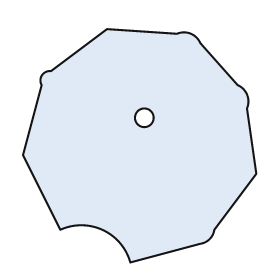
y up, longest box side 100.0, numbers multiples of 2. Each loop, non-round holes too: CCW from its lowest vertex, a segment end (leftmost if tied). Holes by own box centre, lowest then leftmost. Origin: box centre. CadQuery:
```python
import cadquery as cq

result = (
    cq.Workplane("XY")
    .moveTo(-4.0, -50.0)
    .lineTo(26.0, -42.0)
    .threePointArc((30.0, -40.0), (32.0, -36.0))
    .lineTo(50.0, -12.0)
    .lineTo(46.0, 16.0)
    .threePointArc((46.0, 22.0), (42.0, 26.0))
    .lineTo(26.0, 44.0)
    .threePointArc((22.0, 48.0), (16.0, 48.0))
    .lineTo(-14.0, 50.0)
    .lineTo(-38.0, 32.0)
    .threePointArc((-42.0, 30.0), (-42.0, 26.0))
    .lineTo(-50.0, -4.0)
    .lineTo(-34.0, -36.0)
    .threePointArc((-16.0, -36.0), (-4.0, -50.0))
    .close()
    .moveTo(2.0, 12.0)
    .circle(4.0)
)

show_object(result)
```